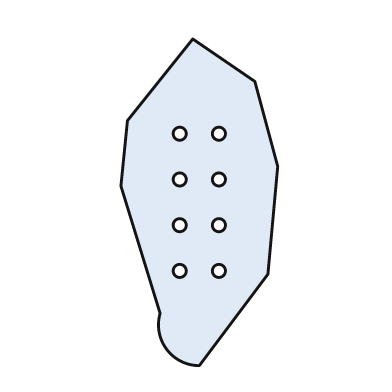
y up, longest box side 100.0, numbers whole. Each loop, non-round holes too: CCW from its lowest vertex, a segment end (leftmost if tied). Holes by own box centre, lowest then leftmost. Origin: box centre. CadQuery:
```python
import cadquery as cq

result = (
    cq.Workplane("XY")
    .moveTo(0.0, -50.0)
    .lineTo(21.0, -22.0)
    .lineTo(24.0, 11.0)
    .lineTo(17.0, 37.0)
    .lineTo(-2.0, 50.0)
    .lineTo(-22.0, 25.0)
    .lineTo(-24.0, 5.0)
    .lineTo(-12.0, -34.0)
    .threePointArc((-10.0, -45.0), (0.0, -50.0))
    .close()
    .moveTo(-6.0, -21.0)
    .circle(2.0)
    .moveTo(6.0, -21.0)
    .circle(2.0)
    .moveTo(-6.0, -7.0)
    .circle(2.0)
    .moveTo(6.0, -7.0)
    .circle(2.0)
    .moveTo(-6.0, 7.0)
    .circle(2.0)
    .moveTo(6.0, 7.0)
    .circle(2.0)
    .moveTo(-6.0, 21.0)
    .circle(2.0)
    .moveTo(6.0, 21.0)
    .circle(2.0)
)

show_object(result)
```